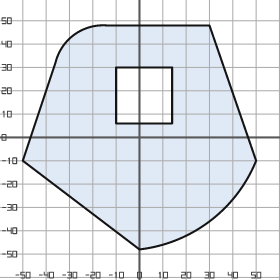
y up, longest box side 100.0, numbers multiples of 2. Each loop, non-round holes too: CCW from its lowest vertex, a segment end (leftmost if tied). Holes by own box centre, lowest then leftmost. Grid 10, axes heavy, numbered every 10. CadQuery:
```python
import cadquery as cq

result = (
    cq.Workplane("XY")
    .moveTo(0.0, -48.0)
    .threePointArc((30.0, -36.0), (50.0, -10.0))
    .lineTo(30.0, 48.0)
    .lineTo(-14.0, 48.0)
    .threePointArc((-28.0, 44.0), (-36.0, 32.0))
    .lineTo(-50.0, -10.0)
    .close()
    .moveTo(-10.0, 6.0)
    .lineTo(14.0, 6.0)
    .lineTo(14.0, 30.0)
    .lineTo(-10.0, 30.0)
    .close()
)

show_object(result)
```